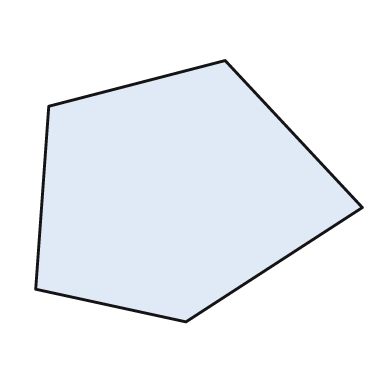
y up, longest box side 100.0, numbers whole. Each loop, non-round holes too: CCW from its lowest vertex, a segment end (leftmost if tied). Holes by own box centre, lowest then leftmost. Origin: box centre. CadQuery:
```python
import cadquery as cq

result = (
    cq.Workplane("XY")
    .moveTo(-4.0, -40.0)
    .lineTo(50.0, -5.0)
    .lineTo(8.0, 40.0)
    .lineTo(-46.0, 26.0)
    .lineTo(-50.0, -30.0)
    .close()
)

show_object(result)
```